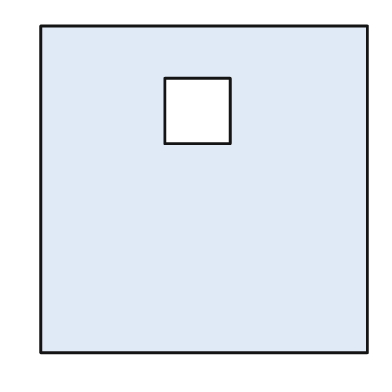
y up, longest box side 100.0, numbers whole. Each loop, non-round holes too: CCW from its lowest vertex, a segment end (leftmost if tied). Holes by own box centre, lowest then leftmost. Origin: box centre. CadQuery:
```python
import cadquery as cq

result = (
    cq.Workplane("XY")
    .moveTo(-50.0, -50.0)
    .lineTo(50.0, -50.0)
    .lineTo(50.0, 50.0)
    .lineTo(-50.0, 50.0)
    .close()
    .moveTo(-12.0, 14.0)
    .lineTo(8.0, 14.0)
    .lineTo(8.0, 34.0)
    .lineTo(-12.0, 34.0)
    .close()
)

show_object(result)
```